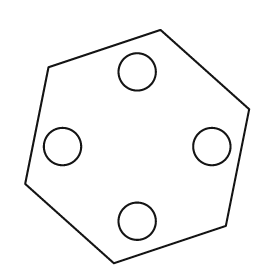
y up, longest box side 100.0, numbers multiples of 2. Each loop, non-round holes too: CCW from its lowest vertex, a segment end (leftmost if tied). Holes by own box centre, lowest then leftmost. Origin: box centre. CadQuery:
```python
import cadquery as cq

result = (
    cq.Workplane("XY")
    .moveTo(-10.0, -50.0)
    .lineTo(38.0, -34.0)
    .lineTo(48.0, 16.0)
    .lineTo(10.0, 50.0)
    .lineTo(-38.0, 34.0)
    .lineTo(-48.0, -16.0)
    .close()
    .moveTo(0.0, -32.0)
    .circle(8.0)
    .moveTo(-32.0, 0.0)
    .circle(8.0)
    .moveTo(32.0, 0.0)
    .circle(8.0)
    .moveTo(0.0, 32.0)
    .circle(8.0)
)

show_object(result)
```